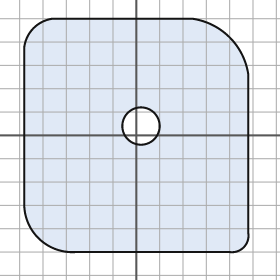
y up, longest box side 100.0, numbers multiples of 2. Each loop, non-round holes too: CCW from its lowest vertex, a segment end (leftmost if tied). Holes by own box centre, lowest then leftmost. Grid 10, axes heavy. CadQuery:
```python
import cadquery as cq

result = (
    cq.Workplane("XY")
    .moveTo(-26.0, -50.0)
    .lineTo(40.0, -50.0)
    .threePointArc((46.0, -48.0), (48.0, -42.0))
    .lineTo(48.0, 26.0)
    .threePointArc((40.0, 42.0), (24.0, 50.0))
    .lineTo(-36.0, 50.0)
    .threePointArc((-44.0, 46.0), (-48.0, 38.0))
    .lineTo(-48.0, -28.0)
    .threePointArc((-42.0, -44.0), (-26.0, -50.0))
    .close()
    .moveTo(2.0, 4.0)
    .circle(8.0)
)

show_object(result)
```